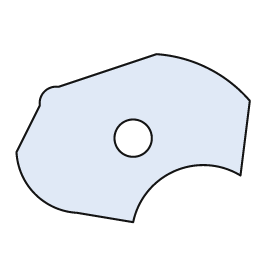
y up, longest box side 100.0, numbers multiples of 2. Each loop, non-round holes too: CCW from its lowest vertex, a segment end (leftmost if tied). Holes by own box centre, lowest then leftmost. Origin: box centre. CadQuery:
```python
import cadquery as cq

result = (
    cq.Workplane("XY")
    .moveTo(0.0, -36.0)
    .threePointArc((18.0, -14.0), (46.0, -16.0))
    .lineTo(50.0, 16.0)
    .threePointArc((32.0, 30.0), (10.0, 36.0))
    .lineTo(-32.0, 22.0)
    .threePointArc((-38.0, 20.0), (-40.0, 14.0))
    .lineTo(-50.0, -6.0)
    .threePointArc((-42.0, -24.0), (-24.0, -32.0))
    .close()
    .moveTo(0.0, 0.0)
    .circle(8.0)
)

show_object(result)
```